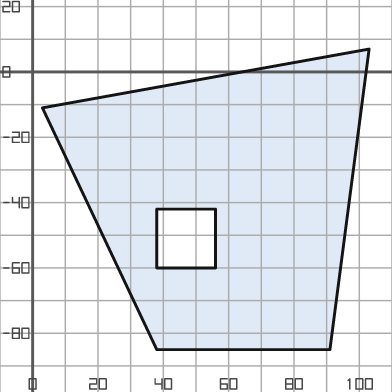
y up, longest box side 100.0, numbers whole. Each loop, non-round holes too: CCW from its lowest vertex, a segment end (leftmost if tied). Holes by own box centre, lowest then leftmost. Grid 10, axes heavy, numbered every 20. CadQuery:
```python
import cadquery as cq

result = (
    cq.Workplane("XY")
    .moveTo(38.0, -85.0)
    .lineTo(91.0, -85.0)
    .lineTo(103.0, 7.0)
    .lineTo(3.0, -11.0)
    .close()
    .moveTo(38.0, -60.0)
    .lineTo(56.0, -60.0)
    .lineTo(56.0, -42.0)
    .lineTo(38.0, -42.0)
    .close()
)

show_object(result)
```